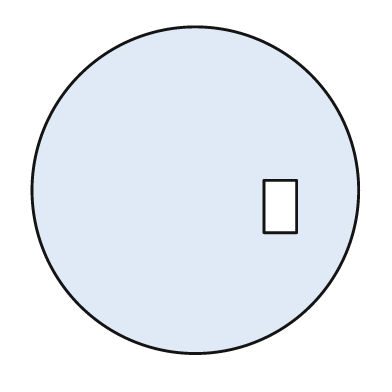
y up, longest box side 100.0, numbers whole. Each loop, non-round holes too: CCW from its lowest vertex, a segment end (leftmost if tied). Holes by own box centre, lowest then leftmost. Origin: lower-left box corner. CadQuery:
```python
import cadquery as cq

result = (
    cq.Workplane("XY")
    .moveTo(50.0, 50.0)
    .circle(50.0)
    .moveTo(71.0, 37.0)
    .lineTo(81.0, 37.0)
    .lineTo(81.0, 53.0)
    .lineTo(71.0, 53.0)
    .close()
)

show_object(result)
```